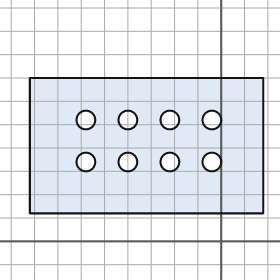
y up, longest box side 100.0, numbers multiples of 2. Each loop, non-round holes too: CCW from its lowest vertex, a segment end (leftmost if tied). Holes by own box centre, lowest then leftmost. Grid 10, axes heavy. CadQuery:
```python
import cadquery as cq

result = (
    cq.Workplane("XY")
    .moveTo(-82.0, 12.0)
    .lineTo(18.0, 12.0)
    .lineTo(18.0, 70.0)
    .lineTo(-82.0, 70.0)
    .close()
    .moveTo(-58.0, 34.0)
    .circle(4.0)
    .moveTo(-40.0, 34.0)
    .circle(4.0)
    .moveTo(-22.0, 34.0)
    .circle(4.0)
    .moveTo(-4.0, 34.0)
    .circle(4.0)
    .moveTo(-58.0, 52.0)
    .circle(4.0)
    .moveTo(-40.0, 52.0)
    .circle(4.0)
    .moveTo(-22.0, 52.0)
    .circle(4.0)
    .moveTo(-4.0, 52.0)
    .circle(4.0)
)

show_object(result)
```